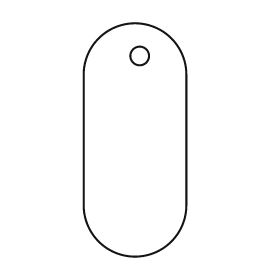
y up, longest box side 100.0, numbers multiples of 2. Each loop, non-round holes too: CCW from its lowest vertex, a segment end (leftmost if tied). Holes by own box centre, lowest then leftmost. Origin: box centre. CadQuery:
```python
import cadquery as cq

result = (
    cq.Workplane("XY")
    .moveTo(-22.0, -28.0)
    .threePointArc((0.0, -50.0), (22.0, -28.0))
    .lineTo(22.0, 28.0)
    .threePointArc((0.0, 50.0), (-22.0, 28.0))
    .close()
    .moveTo(2.0, 36.0)
    .circle(4.0)
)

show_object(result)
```